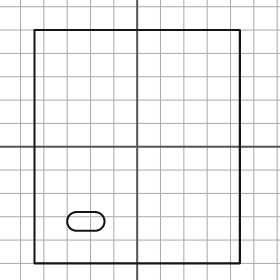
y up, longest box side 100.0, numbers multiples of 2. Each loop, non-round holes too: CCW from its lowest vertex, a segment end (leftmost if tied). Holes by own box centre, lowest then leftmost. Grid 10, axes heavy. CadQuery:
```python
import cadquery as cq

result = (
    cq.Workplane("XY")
    .moveTo(-44.0, -50.0)
    .lineTo(44.0, -50.0)
    .lineTo(44.0, 50.0)
    .lineTo(-44.0, 50.0)
    .close()
    .moveTo(-26.0, -36.0)
    .lineTo(-18.0, -36.0)
    .threePointArc((-14.0, -32.0), (-18.0, -28.0))
    .lineTo(-26.0, -28.0)
    .threePointArc((-30.0, -32.0), (-26.0, -36.0))
    .close()
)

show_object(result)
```